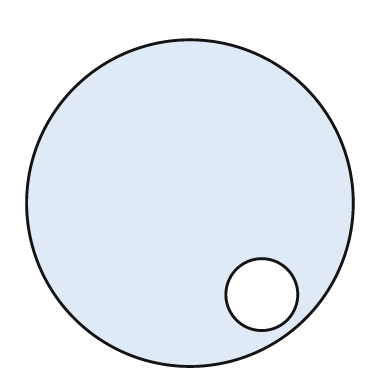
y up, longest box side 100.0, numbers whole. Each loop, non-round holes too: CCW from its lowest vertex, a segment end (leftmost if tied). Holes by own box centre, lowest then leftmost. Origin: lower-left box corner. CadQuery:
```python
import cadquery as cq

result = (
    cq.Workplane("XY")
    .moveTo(50.0, 50.0)
    .circle(50.0)
    .moveTo(72.0, 22.0)
    .circle(11.0)
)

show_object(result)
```